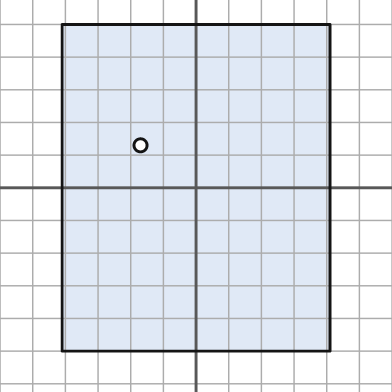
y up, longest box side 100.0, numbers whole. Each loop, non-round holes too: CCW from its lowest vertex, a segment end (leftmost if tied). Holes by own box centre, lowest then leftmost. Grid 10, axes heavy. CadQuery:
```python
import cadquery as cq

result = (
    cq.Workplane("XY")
    .moveTo(-41.0, -50.0)
    .lineTo(41.0, -50.0)
    .lineTo(41.0, 50.0)
    .lineTo(-41.0, 50.0)
    .close()
    .moveTo(-17.0, 13.0)
    .circle(2.0)
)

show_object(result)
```